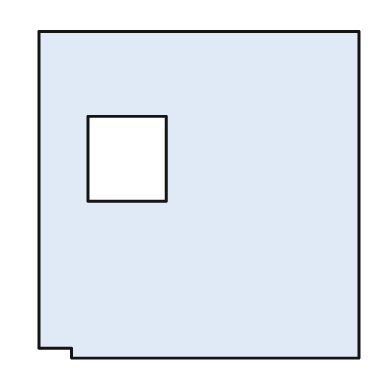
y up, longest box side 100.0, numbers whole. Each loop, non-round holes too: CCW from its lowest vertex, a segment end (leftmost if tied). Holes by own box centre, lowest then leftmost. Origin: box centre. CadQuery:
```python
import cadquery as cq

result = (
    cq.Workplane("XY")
    .moveTo(-39.0, -50.0)
    .lineTo(49.0, -50.0)
    .lineTo(49.0, 50.0)
    .lineTo(-49.0, 50.0)
    .lineTo(-49.0, -47.0)
    .lineTo(-39.0, -47.0)
    .close()
    .moveTo(-34.0, -2.0)
    .lineTo(-10.0, -2.0)
    .lineTo(-10.0, 24.0)
    .lineTo(-34.0, 24.0)
    .close()
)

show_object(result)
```